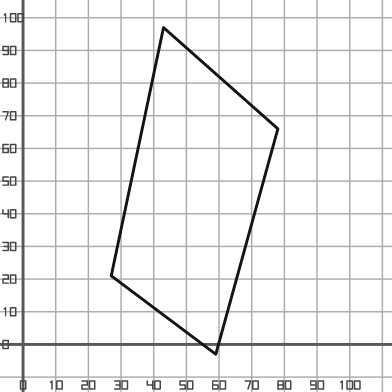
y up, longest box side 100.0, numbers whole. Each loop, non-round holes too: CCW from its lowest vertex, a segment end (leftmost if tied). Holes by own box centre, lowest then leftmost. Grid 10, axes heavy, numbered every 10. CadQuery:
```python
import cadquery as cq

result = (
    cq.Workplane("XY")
    .moveTo(59.0, -3.0)
    .lineTo(78.0, 66.0)
    .lineTo(43.0, 97.0)
    .lineTo(27.0, 21.0)
    .close()
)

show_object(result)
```